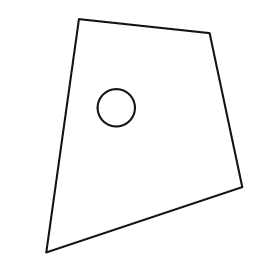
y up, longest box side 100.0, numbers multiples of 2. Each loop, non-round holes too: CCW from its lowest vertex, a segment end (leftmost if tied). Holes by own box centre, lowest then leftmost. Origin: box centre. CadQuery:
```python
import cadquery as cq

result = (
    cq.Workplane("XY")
    .moveTo(-42.0, -50.0)
    .lineTo(42.0, -22.0)
    .lineTo(28.0, 44.0)
    .lineTo(-28.0, 50.0)
    .close()
    .moveTo(-12.0, 12.0)
    .circle(8.0)
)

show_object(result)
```